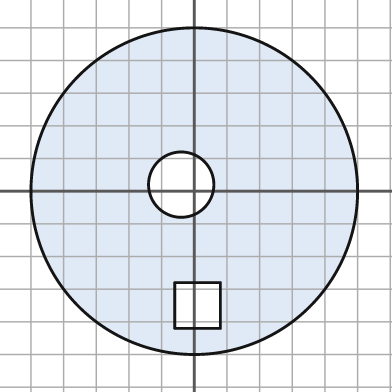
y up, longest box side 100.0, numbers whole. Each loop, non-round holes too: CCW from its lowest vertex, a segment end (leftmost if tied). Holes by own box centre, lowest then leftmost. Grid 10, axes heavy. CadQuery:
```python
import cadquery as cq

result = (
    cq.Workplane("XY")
    .moveTo(0.0, 0.0)
    .circle(50.0)
    .moveTo(-6.0, -42.0)
    .lineTo(8.0, -42.0)
    .lineTo(8.0, -28.0)
    .lineTo(-6.0, -28.0)
    .close()
    .moveTo(-4.0, 2.0)
    .circle(10.0)
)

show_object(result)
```